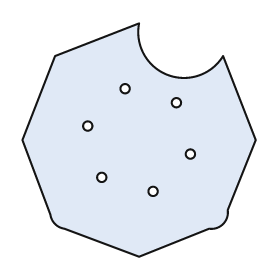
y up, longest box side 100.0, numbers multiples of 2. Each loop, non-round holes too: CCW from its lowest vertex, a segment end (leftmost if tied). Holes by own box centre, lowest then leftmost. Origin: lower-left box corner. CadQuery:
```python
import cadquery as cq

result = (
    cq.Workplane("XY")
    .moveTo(50.0, 0.0)
    .lineTo(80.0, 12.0)
    .threePointArc((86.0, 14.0), (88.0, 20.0))
    .lineTo(100.0, 50.0)
    .lineTo(86.0, 86.0)
    .threePointArc((62.0, 78.0), (50.0, 100.0))
    .lineTo(14.0, 86.0)
    .lineTo(0.0, 50.0)
    .lineTo(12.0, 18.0)
    .threePointArc((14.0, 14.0), (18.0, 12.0))
    .close()
    .moveTo(56.0, 28.0)
    .circle(2.0)
    .moveTo(34.0, 34.0)
    .circle(2.0)
    .moveTo(72.0, 44.0)
    .circle(2.0)
    .moveTo(28.0, 56.0)
    .circle(2.0)
    .moveTo(66.0, 66.0)
    .circle(2.0)
    .moveTo(44.0, 72.0)
    .circle(2.0)
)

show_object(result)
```